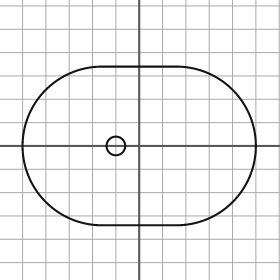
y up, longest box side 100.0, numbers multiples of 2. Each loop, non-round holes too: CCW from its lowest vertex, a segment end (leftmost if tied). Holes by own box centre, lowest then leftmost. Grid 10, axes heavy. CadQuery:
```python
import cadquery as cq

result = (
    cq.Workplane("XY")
    .moveTo(-16.0, -34.0)
    .lineTo(16.0, -34.0)
    .threePointArc((50.0, 0.0), (16.0, 34.0))
    .lineTo(-16.0, 34.0)
    .threePointArc((-50.0, 0.0), (-16.0, -34.0))
    .close()
    .moveTo(-10.0, 0.0)
    .circle(4.0)
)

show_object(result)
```